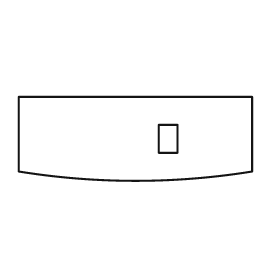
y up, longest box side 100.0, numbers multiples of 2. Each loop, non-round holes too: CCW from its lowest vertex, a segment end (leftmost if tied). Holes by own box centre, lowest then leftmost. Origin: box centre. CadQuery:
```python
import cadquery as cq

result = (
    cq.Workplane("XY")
    .moveTo(-50.0, -14.0)
    .threePointArc((0.0, -18.0), (50.0, -14.0))
    .lineTo(50.0, 18.0)
    .lineTo(-50.0, 18.0)
    .close()
    .moveTo(10.0, -6.0)
    .lineTo(18.0, -6.0)
    .lineTo(18.0, 6.0)
    .lineTo(10.0, 6.0)
    .close()
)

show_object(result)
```